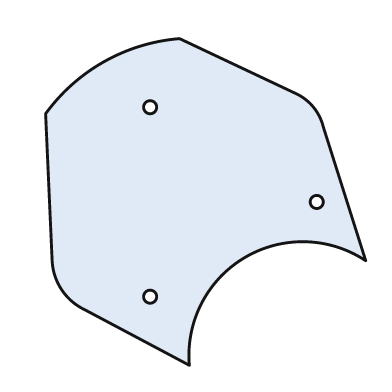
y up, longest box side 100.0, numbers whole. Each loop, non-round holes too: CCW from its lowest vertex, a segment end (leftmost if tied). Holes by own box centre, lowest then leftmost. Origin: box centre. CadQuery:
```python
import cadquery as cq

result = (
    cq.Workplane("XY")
    .moveTo(-5.0, -50.0)
    .threePointArc((12.0, -17.0), (49.0, -18.0))
    .lineTo(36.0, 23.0)
    .threePointArc((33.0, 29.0), (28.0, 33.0))
    .lineTo(-8.0, 50.0)
    .threePointArc((-31.0, 43.0), (-49.0, 27.0))
    .lineTo(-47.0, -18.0)
    .threePointArc((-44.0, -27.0), (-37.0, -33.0))
    .close()
    .moveTo(-17.0, -29.0)
    .circle(2.0)
    .moveTo(34.0, 0.0)
    .circle(2.0)
    .moveTo(-17.0, 29.0)
    .circle(2.0)
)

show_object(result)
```